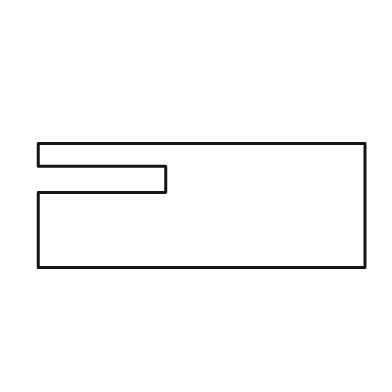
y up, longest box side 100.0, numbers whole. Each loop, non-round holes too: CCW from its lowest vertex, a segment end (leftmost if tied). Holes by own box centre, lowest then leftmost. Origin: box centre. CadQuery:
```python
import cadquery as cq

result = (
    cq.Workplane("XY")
    .moveTo(-50.0, -19.0)
    .lineTo(50.0, -19.0)
    .lineTo(50.0, 19.0)
    .lineTo(-50.0, 19.0)
    .lineTo(-50.0, 12.0)
    .lineTo(-11.0, 12.0)
    .lineTo(-11.0, 4.0)
    .lineTo(-50.0, 4.0)
    .close()
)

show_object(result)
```